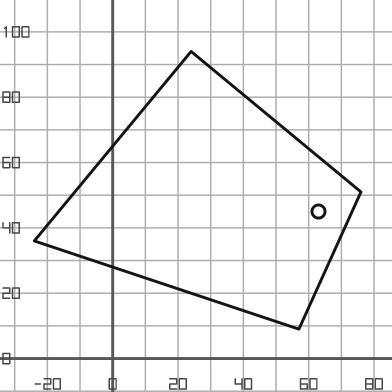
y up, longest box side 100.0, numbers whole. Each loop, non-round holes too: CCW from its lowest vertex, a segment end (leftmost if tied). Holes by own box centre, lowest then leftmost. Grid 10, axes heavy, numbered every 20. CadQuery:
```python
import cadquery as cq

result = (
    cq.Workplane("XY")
    .moveTo(57.0, 9.0)
    .lineTo(76.0, 51.0)
    .lineTo(24.0, 94.0)
    .lineTo(-24.0, 36.0)
    .close()
    .moveTo(63.0, 45.0)
    .circle(2.0)
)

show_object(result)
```